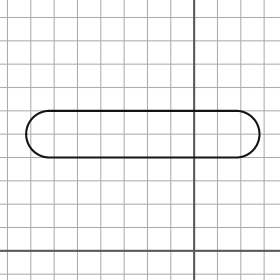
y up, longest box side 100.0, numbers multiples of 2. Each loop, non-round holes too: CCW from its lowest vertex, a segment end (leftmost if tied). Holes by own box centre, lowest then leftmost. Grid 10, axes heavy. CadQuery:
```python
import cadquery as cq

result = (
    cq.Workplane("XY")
    .moveTo(-62.0, 40.0)
    .lineTo(18.0, 40.0)
    .threePointArc((28.0, 50.0), (18.0, 60.0))
    .lineTo(-62.0, 60.0)
    .threePointArc((-72.0, 50.0), (-62.0, 40.0))
    .close()
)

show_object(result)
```